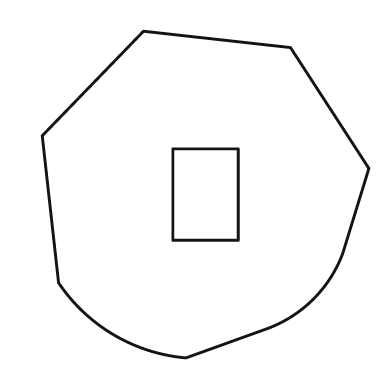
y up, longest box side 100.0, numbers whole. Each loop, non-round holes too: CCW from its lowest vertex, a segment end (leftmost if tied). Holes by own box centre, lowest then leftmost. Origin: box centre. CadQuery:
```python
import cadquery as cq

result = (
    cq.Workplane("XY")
    .moveTo(-6.0, -50.0)
    .lineTo(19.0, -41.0)
    .threePointArc((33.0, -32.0), (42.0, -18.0))
    .lineTo(50.0, 8.0)
    .lineTo(26.0, 45.0)
    .lineTo(-19.0, 50.0)
    .lineTo(-50.0, 18.0)
    .lineTo(-45.0, -27.0)
    .threePointArc((-28.0, -43.0), (-6.0, -50.0))
    .close()
    .moveTo(-10.0, -14.0)
    .lineTo(10.0, -14.0)
    .lineTo(10.0, 14.0)
    .lineTo(-10.0, 14.0)
    .close()
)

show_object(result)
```